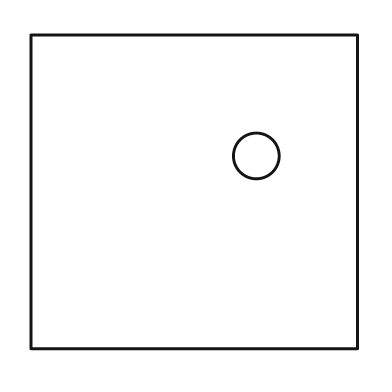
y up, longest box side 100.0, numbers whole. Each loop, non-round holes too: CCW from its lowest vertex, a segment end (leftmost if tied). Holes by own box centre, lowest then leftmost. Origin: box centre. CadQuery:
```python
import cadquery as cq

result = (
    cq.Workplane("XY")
    .moveTo(-50.0, -48.0)
    .lineTo(50.0, -48.0)
    .lineTo(50.0, 48.0)
    .lineTo(-50.0, 48.0)
    .close()
    .moveTo(19.0, 11.0)
    .circle(7.0)
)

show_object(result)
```